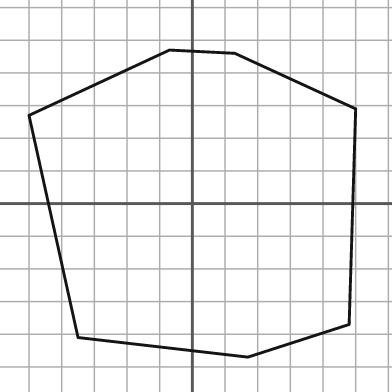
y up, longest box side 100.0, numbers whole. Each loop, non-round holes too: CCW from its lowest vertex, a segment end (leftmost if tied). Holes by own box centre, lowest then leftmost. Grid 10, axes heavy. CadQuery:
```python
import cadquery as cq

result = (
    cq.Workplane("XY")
    .moveTo(17.0, -47.0)
    .lineTo(48.0, -37.0)
    .lineTo(50.0, 29.0)
    .lineTo(13.0, 46.0)
    .lineTo(-7.0, 47.0)
    .lineTo(-50.0, 27.0)
    .lineTo(-35.0, -41.0)
    .close()
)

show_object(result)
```